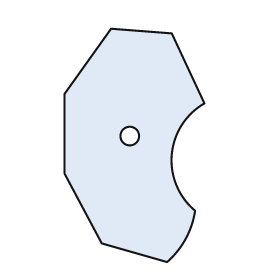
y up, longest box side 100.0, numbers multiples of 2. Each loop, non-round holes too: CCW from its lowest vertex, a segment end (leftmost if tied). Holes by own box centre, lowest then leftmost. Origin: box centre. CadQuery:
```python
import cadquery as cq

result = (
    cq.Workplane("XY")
    .moveTo(14.0, -50.0)
    .threePointArc((22.0, -40.0), (26.0, -28.0))
    .threePointArc((16.0, -4.0), (30.0, 18.0))
    .lineTo(16.0, 48.0)
    .lineTo(-10.0, 50.0)
    .lineTo(-30.0, 22.0)
    .lineTo(-30.0, -12.0)
    .lineTo(-14.0, -42.0)
    .close()
    .moveTo(-2.0, 4.0)
    .circle(4.0)
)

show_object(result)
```